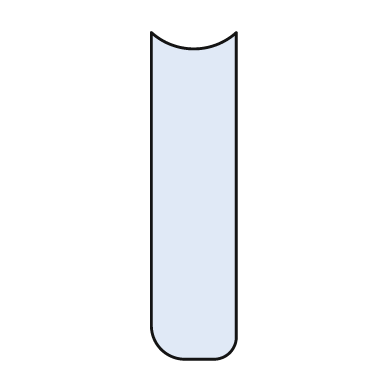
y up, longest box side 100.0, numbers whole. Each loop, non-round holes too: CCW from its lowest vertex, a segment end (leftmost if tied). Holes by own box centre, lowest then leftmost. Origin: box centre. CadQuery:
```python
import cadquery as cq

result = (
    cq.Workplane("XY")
    .moveTo(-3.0, -50.0)
    .lineTo(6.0, -50.0)
    .threePointArc((11.0, -48.0), (13.0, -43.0))
    .lineTo(13.0, 50.0)
    .threePointArc((0.0, 45.0), (-13.0, 50.0))
    .lineTo(-13.0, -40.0)
    .threePointArc((-10.0, -47.0), (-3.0, -50.0))
    .close()
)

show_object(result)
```